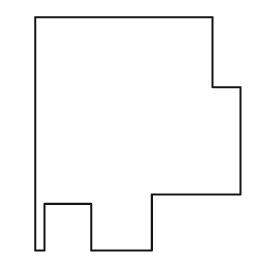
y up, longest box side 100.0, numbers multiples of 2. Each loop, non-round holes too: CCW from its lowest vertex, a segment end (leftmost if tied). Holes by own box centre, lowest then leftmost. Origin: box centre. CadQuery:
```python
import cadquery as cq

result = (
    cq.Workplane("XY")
    .moveTo(-44.0, -50.0)
    .lineTo(-40.0, -50.0)
    .lineTo(-40.0, -30.0)
    .lineTo(-20.0, -30.0)
    .lineTo(-20.0, -50.0)
    .lineTo(6.0, -50.0)
    .lineTo(6.0, -26.0)
    .lineTo(44.0, -26.0)
    .lineTo(44.0, 20.0)
    .lineTo(32.0, 20.0)
    .lineTo(32.0, 50.0)
    .lineTo(-44.0, 50.0)
    .close()
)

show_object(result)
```